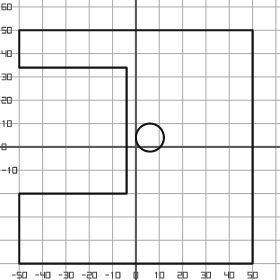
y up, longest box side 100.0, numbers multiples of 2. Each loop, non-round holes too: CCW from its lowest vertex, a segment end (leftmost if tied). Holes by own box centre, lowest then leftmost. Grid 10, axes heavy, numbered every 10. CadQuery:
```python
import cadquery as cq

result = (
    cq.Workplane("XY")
    .moveTo(-50.0, -50.0)
    .lineTo(50.0, -50.0)
    .lineTo(50.0, 50.0)
    .lineTo(-50.0, 50.0)
    .lineTo(-50.0, 34.0)
    .lineTo(-4.0, 34.0)
    .lineTo(-4.0, -20.0)
    .lineTo(-50.0, -20.0)
    .close()
    .moveTo(6.0, 4.0)
    .circle(6.0)
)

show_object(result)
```